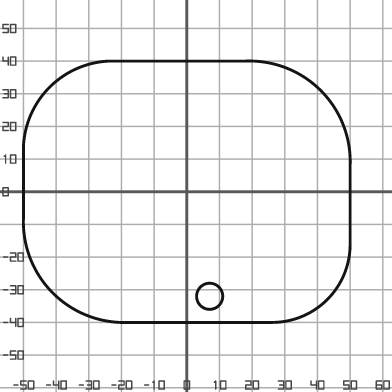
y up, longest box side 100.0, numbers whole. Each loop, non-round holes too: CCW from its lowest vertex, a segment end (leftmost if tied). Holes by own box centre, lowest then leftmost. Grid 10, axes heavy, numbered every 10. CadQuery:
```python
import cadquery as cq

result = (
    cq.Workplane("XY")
    .moveTo(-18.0, -40.0)
    .lineTo(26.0, -40.0)
    .threePointArc((43.0, -33.0), (50.0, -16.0))
    .lineTo(50.0, 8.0)
    .threePointArc((41.0, 31.0), (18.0, 40.0))
    .lineTo(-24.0, 40.0)
    .threePointArc((-42.0, 32.0), (-50.0, 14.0))
    .lineTo(-50.0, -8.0)
    .threePointArc((-41.0, -31.0), (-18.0, -40.0))
    .close()
    .moveTo(7.0, -32.0)
    .circle(4.0)
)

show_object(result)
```